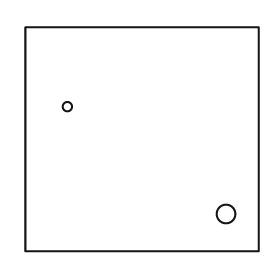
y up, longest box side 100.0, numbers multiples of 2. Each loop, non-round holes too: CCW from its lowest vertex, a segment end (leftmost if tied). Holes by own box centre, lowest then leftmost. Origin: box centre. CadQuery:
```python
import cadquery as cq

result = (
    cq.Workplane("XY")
    .moveTo(-50.0, -48.0)
    .lineTo(50.0, -48.0)
    .lineTo(50.0, 48.0)
    .lineTo(-50.0, 48.0)
    .close()
    .moveTo(36.0, -32.0)
    .circle(4.0)
    .moveTo(-32.0, 14.0)
    .circle(2.0)
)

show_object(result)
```